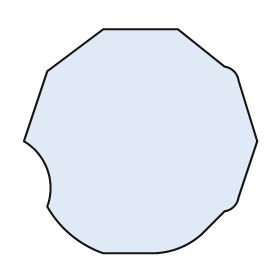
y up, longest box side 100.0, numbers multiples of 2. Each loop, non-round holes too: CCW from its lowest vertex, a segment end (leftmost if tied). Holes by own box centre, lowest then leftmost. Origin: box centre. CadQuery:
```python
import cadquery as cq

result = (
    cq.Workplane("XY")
    .moveTo(-16.0, -48.0)
    .lineTo(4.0, -48.0)
    .threePointArc((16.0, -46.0), (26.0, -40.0))
    .lineTo(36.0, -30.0)
    .threePointArc((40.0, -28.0), (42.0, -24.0))
    .lineTo(50.0, 0.0)
    .lineTo(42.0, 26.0)
    .threePointArc((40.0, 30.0), (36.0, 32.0))
    .lineTo(16.0, 48.0)
    .lineTo(-16.0, 48.0)
    .lineTo(-40.0, 30.0)
    .lineTo(-50.0, 0.0)
    .threePointArc((-40.0, -12.0), (-40.0, -28.0))
    .threePointArc((-30.0, -40.0), (-16.0, -48.0))
    .close()
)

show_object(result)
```